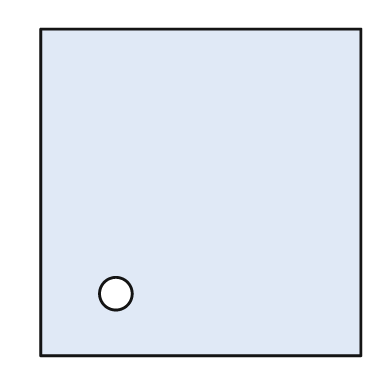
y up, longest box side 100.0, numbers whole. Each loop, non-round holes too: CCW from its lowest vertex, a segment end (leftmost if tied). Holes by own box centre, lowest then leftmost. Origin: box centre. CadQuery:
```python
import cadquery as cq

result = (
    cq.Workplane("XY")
    .moveTo(-49.0, -50.0)
    .lineTo(49.0, -50.0)
    .lineTo(49.0, 50.0)
    .lineTo(-49.0, 50.0)
    .close()
    .moveTo(-26.0, -31.0)
    .circle(5.0)
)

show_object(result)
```